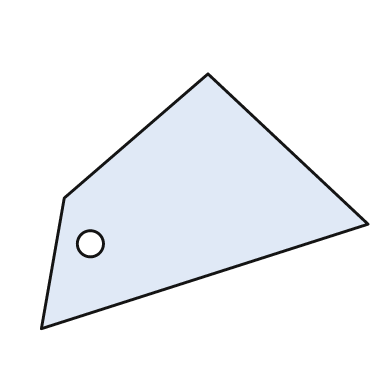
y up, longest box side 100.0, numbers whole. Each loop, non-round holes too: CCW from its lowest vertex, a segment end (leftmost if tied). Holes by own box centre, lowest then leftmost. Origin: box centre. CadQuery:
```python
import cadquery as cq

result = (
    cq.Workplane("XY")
    .moveTo(-50.0, -39.0)
    .lineTo(50.0, -7.0)
    .lineTo(1.0, 39.0)
    .lineTo(-43.0, 1.0)
    .close()
    .moveTo(-35.0, -13.0)
    .circle(4.0)
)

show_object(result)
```